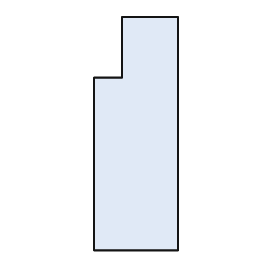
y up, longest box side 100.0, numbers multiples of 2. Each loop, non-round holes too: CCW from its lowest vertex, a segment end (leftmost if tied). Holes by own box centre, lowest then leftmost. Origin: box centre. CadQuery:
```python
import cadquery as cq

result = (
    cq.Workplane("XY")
    .moveTo(-18.0, -50.0)
    .lineTo(18.0, -50.0)
    .lineTo(18.0, 50.0)
    .lineTo(-6.0, 50.0)
    .lineTo(-6.0, 24.0)
    .lineTo(-18.0, 24.0)
    .close()
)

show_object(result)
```